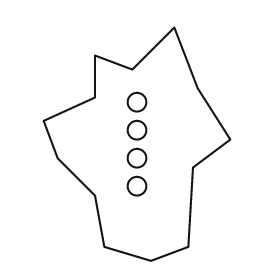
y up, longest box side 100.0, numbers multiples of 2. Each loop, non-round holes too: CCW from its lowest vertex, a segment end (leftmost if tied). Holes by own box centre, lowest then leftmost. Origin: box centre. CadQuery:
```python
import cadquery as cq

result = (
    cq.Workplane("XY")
    .moveTo(6.0, -50.0)
    .lineTo(22.0, -44.0)
    .lineTo(24.0, -10.0)
    .lineTo(40.0, 2.0)
    .lineTo(26.0, 24.0)
    .lineTo(16.0, 50.0)
    .lineTo(-2.0, 32.0)
    .lineTo(-18.0, 38.0)
    .lineTo(-18.0, 20.0)
    .lineTo(-40.0, 10.0)
    .lineTo(-34.0, -6.0)
    .lineTo(-18.0, -22.0)
    .lineTo(-14.0, -44.0)
    .close()
    .moveTo(0.0, -18.0)
    .circle(4.0)
    .moveTo(0.0, -6.0)
    .circle(4.0)
    .moveTo(0.0, 6.0)
    .circle(4.0)
    .moveTo(0.0, 18.0)
    .circle(4.0)
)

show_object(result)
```